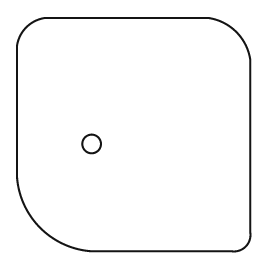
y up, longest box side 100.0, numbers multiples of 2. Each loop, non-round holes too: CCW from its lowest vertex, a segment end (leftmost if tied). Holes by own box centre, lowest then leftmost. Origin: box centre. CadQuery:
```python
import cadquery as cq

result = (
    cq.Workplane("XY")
    .moveTo(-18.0, -50.0)
    .lineTo(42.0, -50.0)
    .threePointArc((48.0, -48.0), (50.0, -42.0))
    .lineTo(50.0, 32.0)
    .threePointArc((44.0, 44.0), (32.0, 50.0))
    .lineTo(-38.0, 50.0)
    .threePointArc((-46.0, 46.0), (-50.0, 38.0))
    .lineTo(-50.0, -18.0)
    .threePointArc((-40.0, -40.0), (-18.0, -50.0))
    .close()
    .moveTo(-18.0, -4.0)
    .circle(4.0)
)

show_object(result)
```